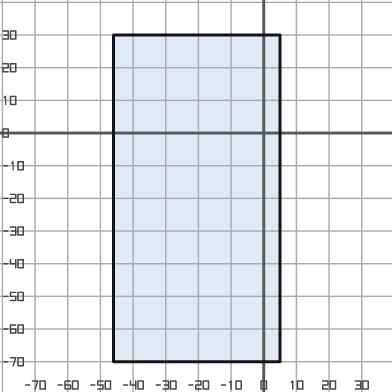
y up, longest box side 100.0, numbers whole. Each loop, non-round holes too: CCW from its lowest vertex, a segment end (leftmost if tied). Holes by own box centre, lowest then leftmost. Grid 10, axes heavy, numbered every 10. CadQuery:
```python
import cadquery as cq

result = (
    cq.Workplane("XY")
    .moveTo(-46.0, -70.0)
    .lineTo(5.0, -70.0)
    .lineTo(5.0, 30.0)
    .lineTo(-46.0, 30.0)
    .close()
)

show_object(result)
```